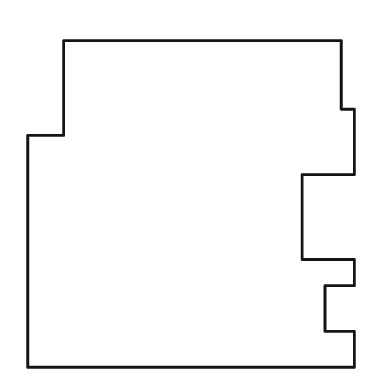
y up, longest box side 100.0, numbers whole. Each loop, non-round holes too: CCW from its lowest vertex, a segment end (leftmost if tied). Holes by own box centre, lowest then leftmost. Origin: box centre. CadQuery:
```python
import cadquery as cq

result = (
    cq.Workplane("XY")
    .moveTo(-50.0, -50.0)
    .lineTo(50.0, -50.0)
    .lineTo(50.0, -39.0)
    .lineTo(41.0, -39.0)
    .lineTo(41.0, -25.0)
    .lineTo(50.0, -25.0)
    .lineTo(50.0, -17.0)
    .lineTo(34.0, -17.0)
    .lineTo(34.0, 9.0)
    .lineTo(50.0, 9.0)
    .lineTo(50.0, 29.0)
    .lineTo(46.0, 29.0)
    .lineTo(46.0, 50.0)
    .lineTo(-39.0, 50.0)
    .lineTo(-39.0, 21.0)
    .lineTo(-50.0, 21.0)
    .close()
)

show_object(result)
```